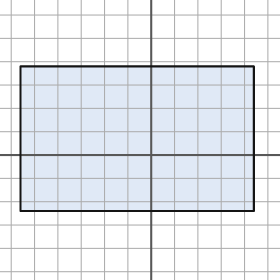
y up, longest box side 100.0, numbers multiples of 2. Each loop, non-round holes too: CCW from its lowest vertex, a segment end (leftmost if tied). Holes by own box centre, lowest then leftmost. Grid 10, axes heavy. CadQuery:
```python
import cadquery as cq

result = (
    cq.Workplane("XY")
    .moveTo(-56.0, -24.0)
    .lineTo(44.0, -24.0)
    .lineTo(44.0, 38.0)
    .lineTo(-56.0, 38.0)
    .close()
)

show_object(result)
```